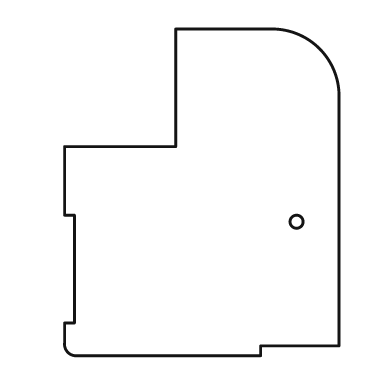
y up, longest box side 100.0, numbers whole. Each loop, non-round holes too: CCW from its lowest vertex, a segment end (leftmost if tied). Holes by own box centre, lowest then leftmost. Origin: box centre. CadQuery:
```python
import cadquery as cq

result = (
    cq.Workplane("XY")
    .moveTo(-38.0, -50.0)
    .lineTo(18.0, -50.0)
    .lineTo(18.0, -47.0)
    .lineTo(42.0, -47.0)
    .lineTo(42.0, 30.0)
    .threePointArc((36.0, 44.0), (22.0, 50.0))
    .lineTo(-8.0, 50.0)
    .lineTo(-8.0, 14.0)
    .lineTo(-42.0, 14.0)
    .lineTo(-42.0, -7.0)
    .lineTo(-39.0, -7.0)
    .lineTo(-39.0, -40.0)
    .lineTo(-42.0, -40.0)
    .lineTo(-42.0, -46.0)
    .threePointArc((-41.0, -49.0), (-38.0, -50.0))
    .close()
    .moveTo(29.0, -9.0)
    .circle(2.0)
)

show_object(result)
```